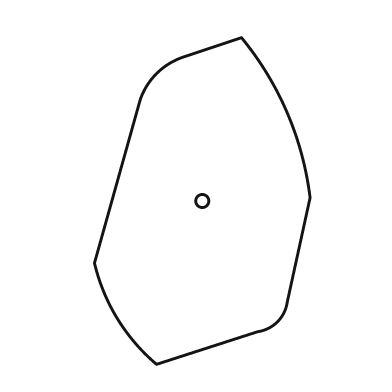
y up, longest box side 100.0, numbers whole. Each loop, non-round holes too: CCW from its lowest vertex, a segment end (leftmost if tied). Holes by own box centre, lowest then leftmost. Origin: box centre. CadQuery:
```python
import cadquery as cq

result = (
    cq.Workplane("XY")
    .moveTo(-14.0, -50.0)
    .lineTo(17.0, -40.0)
    .threePointArc((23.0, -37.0), (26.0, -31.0))
    .lineTo(33.0, 1.0)
    .threePointArc((26.0, 27.0), (12.0, 50.0))
    .lineTo(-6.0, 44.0)
    .threePointArc((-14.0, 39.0), (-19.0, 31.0))
    .lineTo(-33.0, -19.0)
    .threePointArc((-26.0, -36.0), (-14.0, -50.0))
    .close()
    .moveTo(0.0, 0.0)
    .circle(2.0)
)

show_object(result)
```